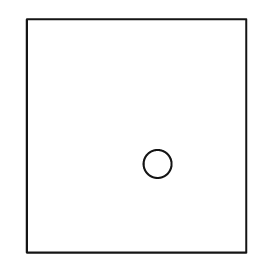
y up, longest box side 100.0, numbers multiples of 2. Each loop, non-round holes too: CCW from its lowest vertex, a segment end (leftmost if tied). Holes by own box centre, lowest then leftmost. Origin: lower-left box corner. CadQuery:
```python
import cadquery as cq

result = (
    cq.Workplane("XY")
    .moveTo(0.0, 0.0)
    .lineTo(94.0, 0.0)
    .lineTo(94.0, 100.0)
    .lineTo(0.0, 100.0)
    .close()
    .moveTo(56.0, 38.0)
    .circle(6.0)
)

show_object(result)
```